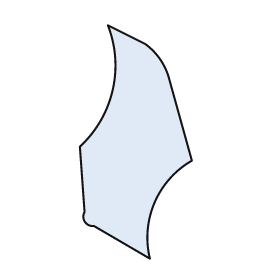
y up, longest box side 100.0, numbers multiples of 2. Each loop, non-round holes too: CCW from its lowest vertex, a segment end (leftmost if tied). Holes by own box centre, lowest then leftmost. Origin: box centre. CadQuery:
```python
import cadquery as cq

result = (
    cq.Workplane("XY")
    .moveTo(6.0, -50.0)
    .threePointArc((8.0, -26.0), (24.0, -8.0))
    .lineTo(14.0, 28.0)
    .threePointArc((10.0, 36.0), (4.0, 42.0))
    .lineTo(-12.0, 50.0)
    .threePointArc((-10.0, 22.0), (-24.0, -2.0))
    .lineTo(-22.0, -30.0)
    .threePointArc((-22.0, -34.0), (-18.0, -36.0))
    .close()
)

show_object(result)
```